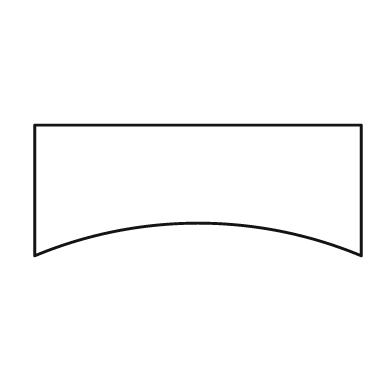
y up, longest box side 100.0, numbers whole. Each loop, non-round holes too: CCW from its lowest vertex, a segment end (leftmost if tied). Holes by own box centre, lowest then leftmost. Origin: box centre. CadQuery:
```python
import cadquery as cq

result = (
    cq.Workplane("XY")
    .moveTo(-50.0, -20.0)
    .threePointArc((0.0, -10.0), (50.0, -20.0))
    .lineTo(50.0, 20.0)
    .lineTo(-50.0, 20.0)
    .close()
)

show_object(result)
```